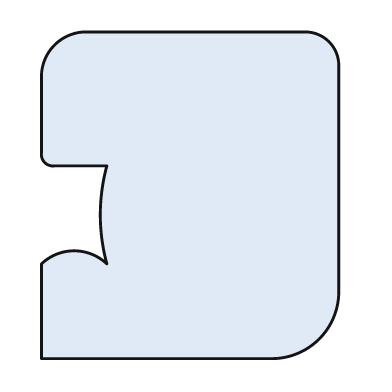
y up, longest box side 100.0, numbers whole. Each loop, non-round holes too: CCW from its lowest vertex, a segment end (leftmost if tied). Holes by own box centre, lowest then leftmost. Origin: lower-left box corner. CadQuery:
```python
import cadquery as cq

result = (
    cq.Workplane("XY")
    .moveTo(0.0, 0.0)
    .lineTo(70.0, 0.0)
    .threePointArc((85.0, 6.0), (91.0, 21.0))
    .lineTo(91.0, 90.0)
    .threePointArc((88.0, 97.0), (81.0, 100.0))
    .lineTo(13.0, 100.0)
    .threePointArc((4.0, 96.0), (0.0, 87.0))
    .lineTo(0.0, 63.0)
    .threePointArc((1.0, 60.0), (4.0, 59.0))
    .lineTo(20.0, 59.0)
    .threePointArc((18.0, 44.0), (20.0, 29.0))
    .threePointArc((10.0, 33.0), (0.0, 29.0))
    .close()
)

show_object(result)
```